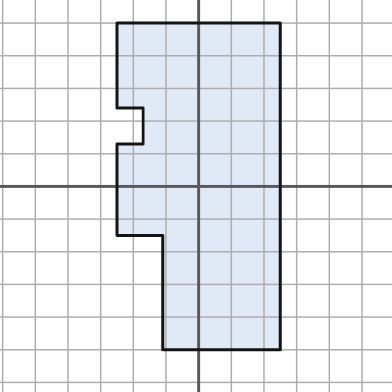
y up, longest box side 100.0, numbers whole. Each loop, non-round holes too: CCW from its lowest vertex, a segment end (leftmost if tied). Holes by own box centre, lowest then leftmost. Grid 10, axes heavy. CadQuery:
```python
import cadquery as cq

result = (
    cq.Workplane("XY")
    .moveTo(-11.0, -50.0)
    .lineTo(25.0, -50.0)
    .lineTo(25.0, 50.0)
    .lineTo(-25.0, 50.0)
    .lineTo(-25.0, 24.0)
    .lineTo(-17.0, 24.0)
    .lineTo(-17.0, 13.0)
    .lineTo(-25.0, 13.0)
    .lineTo(-25.0, -15.0)
    .lineTo(-11.0, -15.0)
    .close()
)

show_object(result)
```